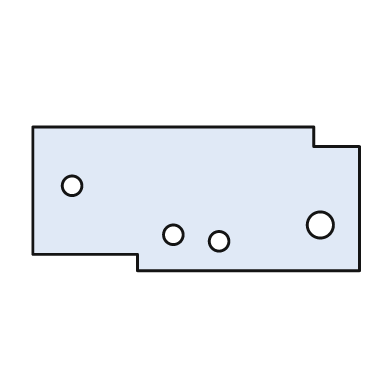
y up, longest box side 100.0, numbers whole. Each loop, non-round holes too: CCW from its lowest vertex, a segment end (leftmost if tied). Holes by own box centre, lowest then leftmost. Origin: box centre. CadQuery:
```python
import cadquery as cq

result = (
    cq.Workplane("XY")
    .moveTo(-18.0, -22.0)
    .lineTo(50.0, -22.0)
    .lineTo(50.0, 16.0)
    .lineTo(36.0, 16.0)
    .lineTo(36.0, 22.0)
    .lineTo(-50.0, 22.0)
    .lineTo(-50.0, -17.0)
    .lineTo(-18.0, -17.0)
    .close()
    .moveTo(7.0, -13.0)
    .circle(3.0)
    .moveTo(-7.0, -11.0)
    .circle(3.0)
    .moveTo(38.0, -8.0)
    .circle(4.0)
    .moveTo(-38.0, 4.0)
    .circle(3.0)
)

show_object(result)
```